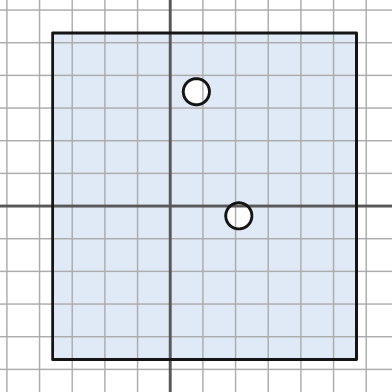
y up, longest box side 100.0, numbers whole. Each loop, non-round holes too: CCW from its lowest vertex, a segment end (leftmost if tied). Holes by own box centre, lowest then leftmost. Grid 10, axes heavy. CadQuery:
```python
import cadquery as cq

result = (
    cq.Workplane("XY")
    .moveTo(-36.0, -47.0)
    .lineTo(57.0, -47.0)
    .lineTo(57.0, 53.0)
    .lineTo(-36.0, 53.0)
    .close()
    .moveTo(21.0, -3.0)
    .circle(4.0)
    .moveTo(8.0, 35.0)
    .circle(4.0)
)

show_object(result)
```